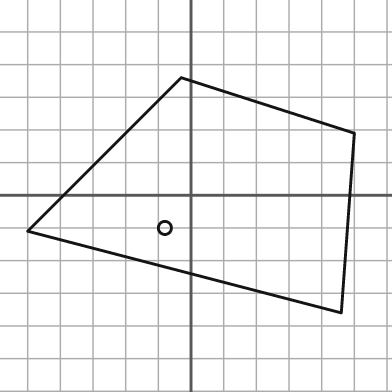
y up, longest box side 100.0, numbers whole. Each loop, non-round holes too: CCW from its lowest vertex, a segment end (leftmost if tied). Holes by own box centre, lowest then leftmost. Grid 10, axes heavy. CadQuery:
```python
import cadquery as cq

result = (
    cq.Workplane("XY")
    .moveTo(46.0, -36.0)
    .lineTo(50.0, 19.0)
    .lineTo(-3.0, 36.0)
    .lineTo(-50.0, -11.0)
    .close()
    .moveTo(-8.0, -10.0)
    .circle(2.0)
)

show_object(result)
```